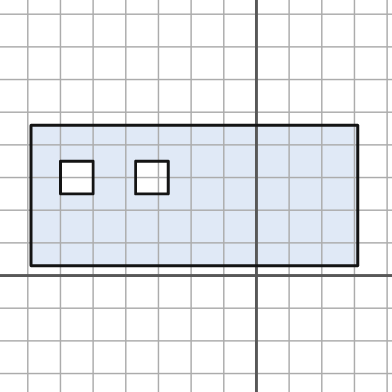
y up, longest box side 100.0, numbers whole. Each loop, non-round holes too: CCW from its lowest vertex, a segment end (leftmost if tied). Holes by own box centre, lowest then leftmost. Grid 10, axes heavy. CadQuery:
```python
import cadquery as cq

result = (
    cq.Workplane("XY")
    .moveTo(-69.0, 3.0)
    .lineTo(31.0, 3.0)
    .lineTo(31.0, 46.0)
    .lineTo(-69.0, 46.0)
    .close()
    .moveTo(-60.0, 25.0)
    .lineTo(-50.0, 25.0)
    .lineTo(-50.0, 35.0)
    .lineTo(-60.0, 35.0)
    .close()
    .moveTo(-37.0, 25.0)
    .lineTo(-27.0, 25.0)
    .lineTo(-27.0, 35.0)
    .lineTo(-37.0, 35.0)
    .close()
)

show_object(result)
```